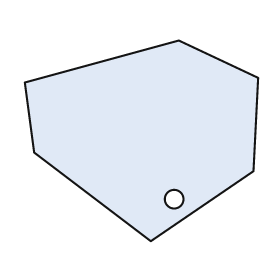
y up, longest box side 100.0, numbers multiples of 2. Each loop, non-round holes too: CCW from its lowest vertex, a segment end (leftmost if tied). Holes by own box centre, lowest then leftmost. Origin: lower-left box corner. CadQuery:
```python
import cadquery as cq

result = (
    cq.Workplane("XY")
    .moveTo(54.0, 0.0)
    .lineTo(98.0, 30.0)
    .lineTo(100.0, 70.0)
    .lineTo(66.0, 86.0)
    .lineTo(0.0, 68.0)
    .lineTo(4.0, 38.0)
    .close()
    .moveTo(64.0, 18.0)
    .circle(4.0)
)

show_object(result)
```